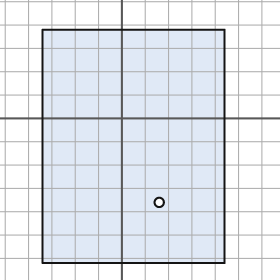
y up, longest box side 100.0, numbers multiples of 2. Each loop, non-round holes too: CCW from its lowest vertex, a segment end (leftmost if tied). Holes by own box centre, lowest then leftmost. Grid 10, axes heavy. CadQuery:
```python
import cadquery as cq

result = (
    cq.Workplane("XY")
    .moveTo(-34.0, -62.0)
    .lineTo(44.0, -62.0)
    .lineTo(44.0, 38.0)
    .lineTo(-34.0, 38.0)
    .close()
    .moveTo(16.0, -36.0)
    .circle(2.0)
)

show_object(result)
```